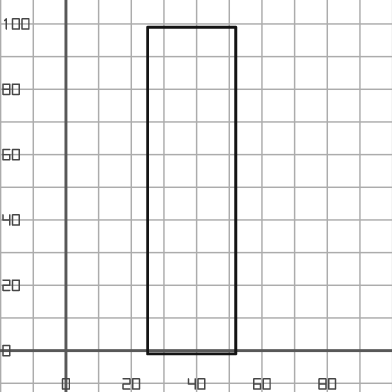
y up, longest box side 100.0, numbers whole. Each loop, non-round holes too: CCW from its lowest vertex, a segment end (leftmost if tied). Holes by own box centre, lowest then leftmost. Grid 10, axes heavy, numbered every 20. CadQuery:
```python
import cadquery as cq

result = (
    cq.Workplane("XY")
    .moveTo(25.0, -1.0)
    .lineTo(52.0, -1.0)
    .lineTo(52.0, 99.0)
    .lineTo(25.0, 99.0)
    .close()
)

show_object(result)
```